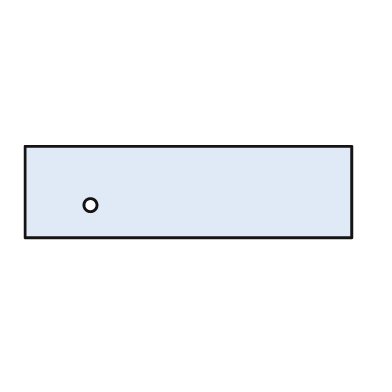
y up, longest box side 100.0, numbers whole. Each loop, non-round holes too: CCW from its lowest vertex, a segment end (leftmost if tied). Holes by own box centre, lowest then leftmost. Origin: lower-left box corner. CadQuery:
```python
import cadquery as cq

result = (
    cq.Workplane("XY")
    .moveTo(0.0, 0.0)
    .lineTo(100.0, 0.0)
    .lineTo(100.0, 28.0)
    .lineTo(0.0, 28.0)
    .close()
    .moveTo(20.0, 10.0)
    .circle(2.0)
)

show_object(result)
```